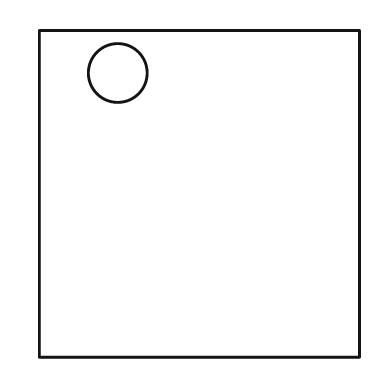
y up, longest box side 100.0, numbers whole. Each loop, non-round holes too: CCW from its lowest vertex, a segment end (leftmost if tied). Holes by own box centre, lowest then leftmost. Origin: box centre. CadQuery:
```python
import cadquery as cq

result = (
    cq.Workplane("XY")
    .moveTo(-49.0, -50.0)
    .lineTo(49.0, -50.0)
    .lineTo(49.0, 50.0)
    .lineTo(-49.0, 50.0)
    .close()
    .moveTo(-25.0, 37.0)
    .circle(9.0)
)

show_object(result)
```